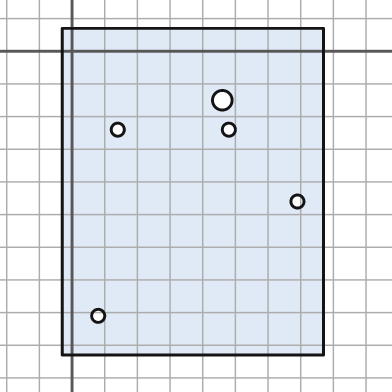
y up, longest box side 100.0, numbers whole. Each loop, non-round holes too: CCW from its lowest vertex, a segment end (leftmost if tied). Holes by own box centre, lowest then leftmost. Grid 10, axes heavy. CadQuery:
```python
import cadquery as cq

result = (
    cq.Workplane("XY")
    .moveTo(-3.0, -93.0)
    .lineTo(77.0, -93.0)
    .lineTo(77.0, 7.0)
    .lineTo(-3.0, 7.0)
    .close()
    .moveTo(8.0, -81.0)
    .circle(2.0)
    .moveTo(69.0, -46.0)
    .circle(2.0)
    .moveTo(14.0, -24.0)
    .circle(2.0)
    .moveTo(48.0, -24.0)
    .circle(2.0)
    .moveTo(46.0, -15.0)
    .circle(3.0)
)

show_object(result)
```